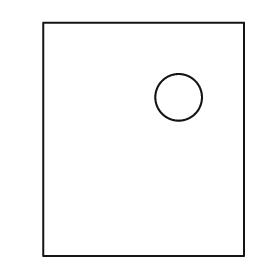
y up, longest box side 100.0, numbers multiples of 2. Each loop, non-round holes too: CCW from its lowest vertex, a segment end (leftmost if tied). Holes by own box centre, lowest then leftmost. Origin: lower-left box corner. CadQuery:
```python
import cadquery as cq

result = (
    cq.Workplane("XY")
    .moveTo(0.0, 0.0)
    .lineTo(86.0, 0.0)
    .lineTo(86.0, 100.0)
    .lineTo(0.0, 100.0)
    .close()
    .moveTo(58.0, 68.0)
    .circle(10.0)
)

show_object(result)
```